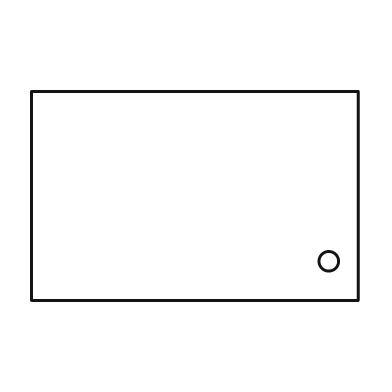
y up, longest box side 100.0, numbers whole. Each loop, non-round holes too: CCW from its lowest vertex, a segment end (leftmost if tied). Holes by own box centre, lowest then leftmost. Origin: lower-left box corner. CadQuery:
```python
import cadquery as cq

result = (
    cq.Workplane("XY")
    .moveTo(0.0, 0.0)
    .lineTo(100.0, 0.0)
    .lineTo(100.0, 64.0)
    .lineTo(0.0, 64.0)
    .close()
    .moveTo(91.0, 12.0)
    .circle(3.0)
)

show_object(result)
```